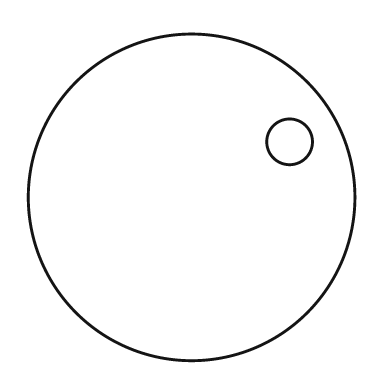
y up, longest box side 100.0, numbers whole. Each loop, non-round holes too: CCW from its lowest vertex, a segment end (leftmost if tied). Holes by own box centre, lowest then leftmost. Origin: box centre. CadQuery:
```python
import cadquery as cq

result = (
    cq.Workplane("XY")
    .moveTo(0.0, 0.0)
    .circle(50.0)
    .moveTo(30.0, 17.0)
    .circle(7.0)
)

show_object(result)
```